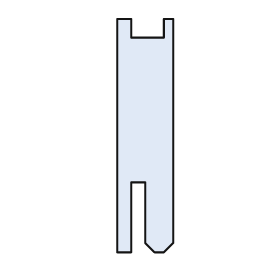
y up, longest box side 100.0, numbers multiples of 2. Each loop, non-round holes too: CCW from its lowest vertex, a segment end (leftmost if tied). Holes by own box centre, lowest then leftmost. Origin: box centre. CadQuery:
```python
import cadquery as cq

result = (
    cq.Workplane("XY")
    .moveTo(-12.0, -50.0)
    .lineTo(-6.0, -50.0)
    .lineTo(-6.0, -20.0)
    .lineTo(0.0, -20.0)
    .lineTo(0.0, -46.0)
    .lineTo(4.0, -50.0)
    .lineTo(8.0, -50.0)
    .lineTo(12.0, -46.0)
    .lineTo(12.0, 50.0)
    .lineTo(8.0, 50.0)
    .lineTo(8.0, 42.0)
    .lineTo(-6.0, 42.0)
    .lineTo(-6.0, 50.0)
    .lineTo(-12.0, 50.0)
    .close()
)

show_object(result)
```